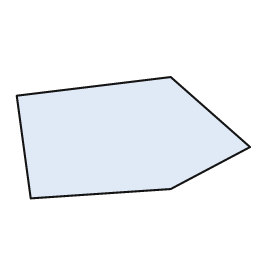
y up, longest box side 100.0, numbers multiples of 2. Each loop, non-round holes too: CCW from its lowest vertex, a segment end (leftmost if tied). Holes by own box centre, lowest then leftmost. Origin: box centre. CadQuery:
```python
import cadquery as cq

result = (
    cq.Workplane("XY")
    .moveTo(-44.0, -26.0)
    .lineTo(16.0, -22.0)
    .lineTo(50.0, -4.0)
    .lineTo(16.0, 26.0)
    .lineTo(-50.0, 18.0)
    .close()
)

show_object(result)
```